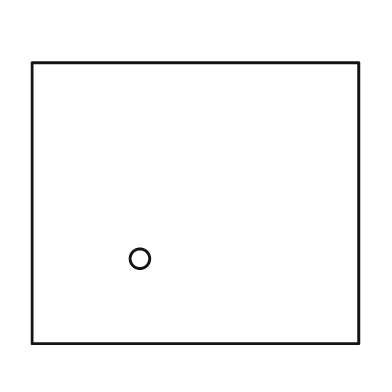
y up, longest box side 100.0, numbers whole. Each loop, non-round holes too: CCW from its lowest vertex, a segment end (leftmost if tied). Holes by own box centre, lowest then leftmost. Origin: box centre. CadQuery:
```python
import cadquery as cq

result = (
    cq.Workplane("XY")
    .moveTo(-50.0, -43.0)
    .lineTo(50.0, -43.0)
    .lineTo(50.0, 43.0)
    .lineTo(-50.0, 43.0)
    .close()
    .moveTo(-17.0, -17.0)
    .circle(3.0)
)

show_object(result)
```